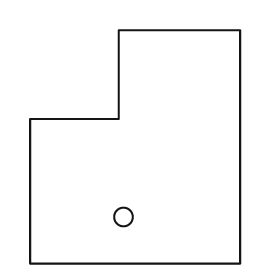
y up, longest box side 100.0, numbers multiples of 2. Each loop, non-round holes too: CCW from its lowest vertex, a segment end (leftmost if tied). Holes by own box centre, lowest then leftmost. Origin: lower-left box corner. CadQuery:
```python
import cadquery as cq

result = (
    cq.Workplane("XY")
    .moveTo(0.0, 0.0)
    .lineTo(90.0, 0.0)
    .lineTo(90.0, 100.0)
    .lineTo(38.0, 100.0)
    .lineTo(38.0, 62.0)
    .lineTo(0.0, 62.0)
    .close()
    .moveTo(40.0, 20.0)
    .circle(4.0)
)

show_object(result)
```